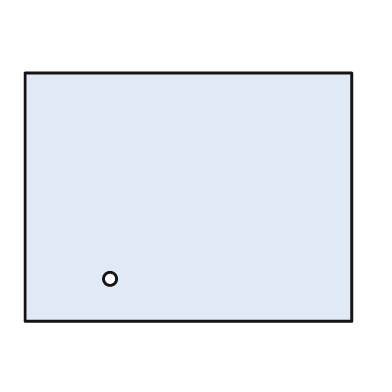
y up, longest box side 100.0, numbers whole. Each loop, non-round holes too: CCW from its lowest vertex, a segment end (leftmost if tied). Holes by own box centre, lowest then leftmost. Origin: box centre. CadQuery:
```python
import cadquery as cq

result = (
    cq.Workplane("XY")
    .moveTo(-50.0, -38.0)
    .lineTo(50.0, -38.0)
    .lineTo(50.0, 38.0)
    .lineTo(-50.0, 38.0)
    .close()
    .moveTo(-24.0, -25.0)
    .circle(2.0)
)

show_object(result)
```